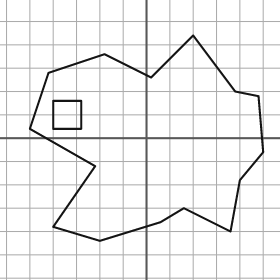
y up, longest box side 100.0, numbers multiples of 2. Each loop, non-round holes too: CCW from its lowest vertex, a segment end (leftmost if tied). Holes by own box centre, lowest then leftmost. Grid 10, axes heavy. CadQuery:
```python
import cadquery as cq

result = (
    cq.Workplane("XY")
    .moveTo(-20.0, -44.0)
    .lineTo(6.0, -36.0)
    .lineTo(16.0, -30.0)
    .lineTo(36.0, -40.0)
    .lineTo(40.0, -18.0)
    .lineTo(50.0, -6.0)
    .lineTo(48.0, 18.0)
    .lineTo(38.0, 20.0)
    .lineTo(20.0, 44.0)
    .lineTo(2.0, 26.0)
    .lineTo(-18.0, 36.0)
    .lineTo(-42.0, 28.0)
    .lineTo(-50.0, 4.0)
    .lineTo(-22.0, -12.0)
    .lineTo(-40.0, -38.0)
    .close()
    .moveTo(-40.0, 4.0)
    .lineTo(-28.0, 4.0)
    .lineTo(-28.0, 16.0)
    .lineTo(-40.0, 16.0)
    .close()
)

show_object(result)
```